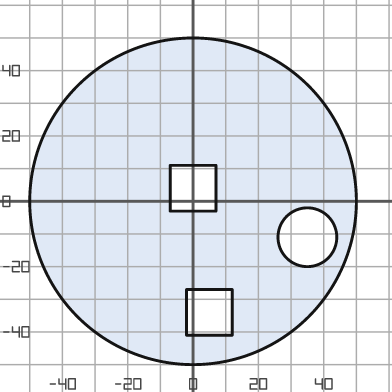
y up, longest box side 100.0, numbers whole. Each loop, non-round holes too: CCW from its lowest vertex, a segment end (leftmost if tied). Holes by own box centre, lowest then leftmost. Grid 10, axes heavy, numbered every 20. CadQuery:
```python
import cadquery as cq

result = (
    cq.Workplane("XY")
    .moveTo(0.0, 0.0)
    .circle(50.0)
    .moveTo(-2.0, -41.0)
    .lineTo(12.0, -41.0)
    .lineTo(12.0, -27.0)
    .lineTo(-2.0, -27.0)
    .close()
    .moveTo(35.0, -11.0)
    .circle(9.0)
    .moveTo(-7.0, -3.0)
    .lineTo(7.0, -3.0)
    .lineTo(7.0, 11.0)
    .lineTo(-7.0, 11.0)
    .close()
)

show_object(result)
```